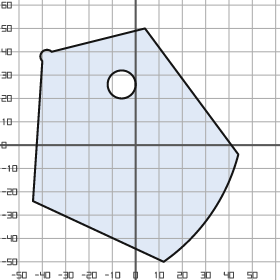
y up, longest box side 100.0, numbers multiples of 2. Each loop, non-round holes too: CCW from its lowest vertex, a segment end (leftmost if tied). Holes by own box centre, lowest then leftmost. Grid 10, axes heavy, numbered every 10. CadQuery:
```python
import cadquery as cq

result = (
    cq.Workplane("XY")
    .moveTo(12.0, -50.0)
    .threePointArc((32.0, -30.0), (44.0, -4.0))
    .lineTo(4.0, 50.0)
    .lineTo(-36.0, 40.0)
    .threePointArc((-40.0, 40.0), (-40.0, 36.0))
    .lineTo(-44.0, -24.0)
    .close()
    .moveTo(-6.0, 26.0)
    .circle(6.0)
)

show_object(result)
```